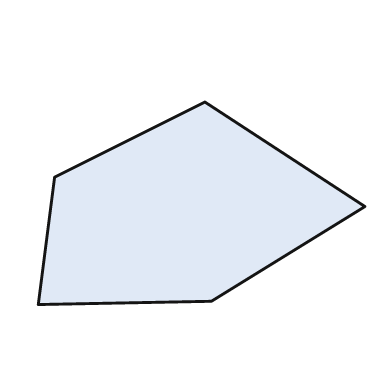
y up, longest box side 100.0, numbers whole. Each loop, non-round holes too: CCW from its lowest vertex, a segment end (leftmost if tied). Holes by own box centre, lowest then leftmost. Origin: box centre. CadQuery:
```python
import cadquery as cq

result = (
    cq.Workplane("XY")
    .moveTo(-50.0, -31.0)
    .lineTo(3.0, -30.0)
    .lineTo(50.0, -1.0)
    .lineTo(1.0, 31.0)
    .lineTo(-45.0, 8.0)
    .close()
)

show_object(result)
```